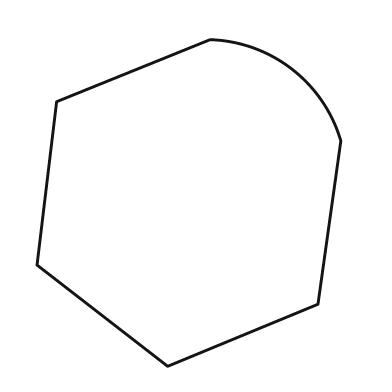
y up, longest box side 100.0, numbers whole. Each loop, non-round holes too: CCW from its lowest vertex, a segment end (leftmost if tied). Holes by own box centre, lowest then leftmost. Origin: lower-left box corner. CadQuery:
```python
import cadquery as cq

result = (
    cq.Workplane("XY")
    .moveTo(40.0, 0.0)
    .lineTo(86.0, 19.0)
    .lineTo(93.0, 69.0)
    .threePointArc((78.0, 91.0), (53.0, 100.0))
    .lineTo(6.0, 81.0)
    .lineTo(0.0, 31.0)
    .close()
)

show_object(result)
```